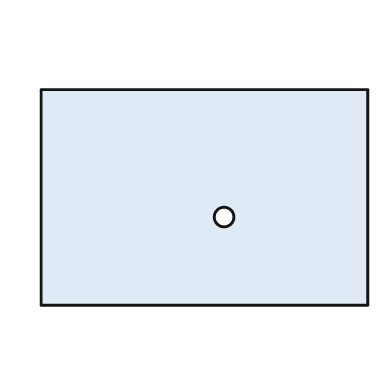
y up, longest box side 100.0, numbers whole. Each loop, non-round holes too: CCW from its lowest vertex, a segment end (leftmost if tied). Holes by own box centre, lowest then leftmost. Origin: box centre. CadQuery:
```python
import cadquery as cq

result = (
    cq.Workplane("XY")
    .moveTo(-50.0, -33.0)
    .lineTo(50.0, -33.0)
    .lineTo(50.0, 33.0)
    .lineTo(-50.0, 33.0)
    .close()
    .moveTo(6.0, -6.0)
    .circle(3.0)
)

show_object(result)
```